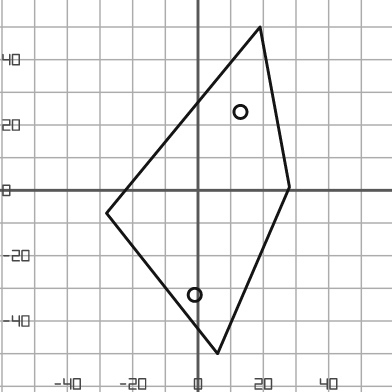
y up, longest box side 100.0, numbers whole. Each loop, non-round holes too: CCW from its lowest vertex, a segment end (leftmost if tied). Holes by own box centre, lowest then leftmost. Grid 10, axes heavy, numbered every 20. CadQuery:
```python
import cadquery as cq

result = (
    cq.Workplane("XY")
    .moveTo(6.0, -50.0)
    .lineTo(28.0, 1.0)
    .lineTo(19.0, 50.0)
    .lineTo(-28.0, -7.0)
    .close()
    .moveTo(-1.0, -32.0)
    .circle(2.0)
    .moveTo(13.0, 24.0)
    .circle(2.0)
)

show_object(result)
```